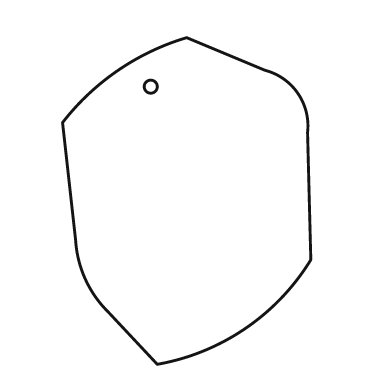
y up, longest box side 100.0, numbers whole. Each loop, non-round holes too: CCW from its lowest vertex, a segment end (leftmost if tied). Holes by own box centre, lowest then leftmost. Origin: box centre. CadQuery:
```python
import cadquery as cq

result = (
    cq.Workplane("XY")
    .moveTo(-9.0, -50.0)
    .threePointArc((18.0, -39.0), (38.0, -18.0))
    .lineTo(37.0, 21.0)
    .threePointArc((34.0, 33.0), (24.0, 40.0))
    .lineTo(0.0, 50.0)
    .threePointArc((-21.0, 40.0), (-38.0, 24.0))
    .lineTo(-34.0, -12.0)
    .threePointArc((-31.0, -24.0), (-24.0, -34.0))
    .close()
    .moveTo(-11.0, 35.0)
    .circle(2.0)
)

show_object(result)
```